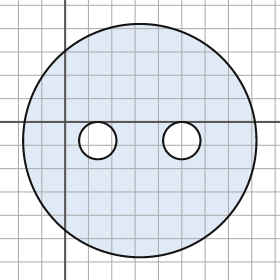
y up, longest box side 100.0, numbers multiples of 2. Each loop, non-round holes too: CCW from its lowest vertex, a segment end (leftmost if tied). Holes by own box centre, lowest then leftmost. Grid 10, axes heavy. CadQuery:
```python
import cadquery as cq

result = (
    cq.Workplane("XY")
    .moveTo(32.0, -8.0)
    .circle(50.0)
    .moveTo(14.0, -8.0)
    .circle(8.0)
    .moveTo(50.0, -8.0)
    .circle(8.0)
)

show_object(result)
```